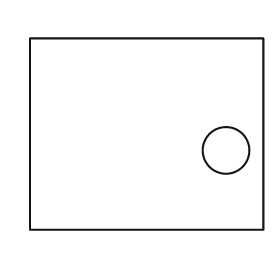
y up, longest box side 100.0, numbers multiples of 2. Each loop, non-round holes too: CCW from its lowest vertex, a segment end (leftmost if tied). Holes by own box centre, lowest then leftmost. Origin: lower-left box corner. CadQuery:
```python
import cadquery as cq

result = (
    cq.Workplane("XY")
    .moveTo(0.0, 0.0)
    .lineTo(100.0, 0.0)
    .lineTo(100.0, 82.0)
    .lineTo(0.0, 82.0)
    .close()
    .moveTo(84.0, 34.0)
    .circle(10.0)
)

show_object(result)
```